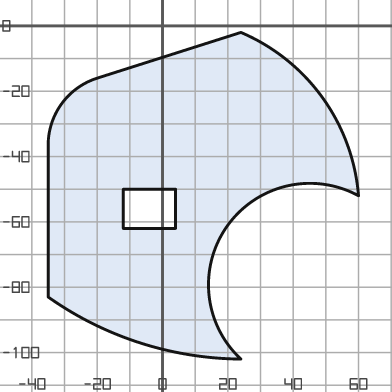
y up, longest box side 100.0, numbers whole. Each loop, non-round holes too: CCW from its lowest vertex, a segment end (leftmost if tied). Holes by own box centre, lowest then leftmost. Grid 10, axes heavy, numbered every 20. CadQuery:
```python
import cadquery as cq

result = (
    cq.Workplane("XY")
    .moveTo(24.0, -102.0)
    .threePointArc((20.0, -61.0), (60.0, -52.0))
    .threePointArc((49.0, -22.0), (24.0, -2.0))
    .lineTo(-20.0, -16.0)
    .threePointArc((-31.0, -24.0), (-35.0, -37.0))
    .lineTo(-35.0, -83.0)
    .threePointArc((-7.0, -97.0), (24.0, -102.0))
    .close()
    .moveTo(-12.0, -62.0)
    .lineTo(4.0, -62.0)
    .lineTo(4.0, -50.0)
    .lineTo(-12.0, -50.0)
    .close()
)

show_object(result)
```